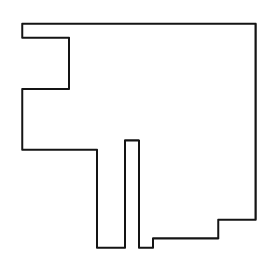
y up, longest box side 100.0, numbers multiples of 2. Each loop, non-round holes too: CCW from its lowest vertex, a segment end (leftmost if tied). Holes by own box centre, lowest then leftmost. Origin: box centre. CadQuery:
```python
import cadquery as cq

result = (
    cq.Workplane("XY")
    .moveTo(-18.0, -48.0)
    .lineTo(-6.0, -48.0)
    .lineTo(-6.0, -2.0)
    .lineTo(0.0, -2.0)
    .lineTo(0.0, -48.0)
    .lineTo(6.0, -48.0)
    .lineTo(6.0, -44.0)
    .lineTo(34.0, -44.0)
    .lineTo(34.0, -36.0)
    .lineTo(50.0, -36.0)
    .lineTo(50.0, 48.0)
    .lineTo(-50.0, 48.0)
    .lineTo(-50.0, 42.0)
    .lineTo(-30.0, 42.0)
    .lineTo(-30.0, 20.0)
    .lineTo(-50.0, 20.0)
    .lineTo(-50.0, -6.0)
    .lineTo(-18.0, -6.0)
    .close()
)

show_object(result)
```